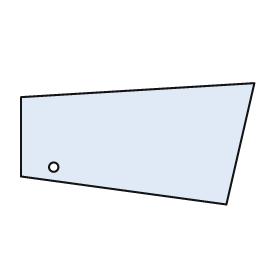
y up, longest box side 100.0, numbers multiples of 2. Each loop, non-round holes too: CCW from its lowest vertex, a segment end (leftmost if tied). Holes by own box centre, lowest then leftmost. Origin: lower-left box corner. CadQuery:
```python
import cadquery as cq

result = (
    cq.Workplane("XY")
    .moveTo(88.0, 0.0)
    .lineTo(100.0, 52.0)
    .lineTo(0.0, 46.0)
    .lineTo(0.0, 12.0)
    .close()
    .moveTo(14.0, 16.0)
    .circle(2.0)
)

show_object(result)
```